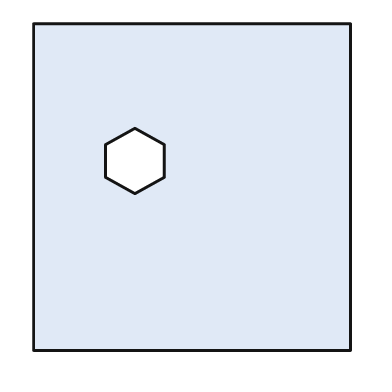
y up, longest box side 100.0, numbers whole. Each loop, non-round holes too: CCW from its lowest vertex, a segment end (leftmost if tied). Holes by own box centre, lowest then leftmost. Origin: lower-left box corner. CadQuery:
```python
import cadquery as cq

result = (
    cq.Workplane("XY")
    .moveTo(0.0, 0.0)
    .lineTo(97.0, 0.0)
    .lineTo(97.0, 100.0)
    .lineTo(0.0, 100.0)
    .close()
    .moveTo(31.0, 48.0)
    .lineTo(40.0, 53.0)
    .lineTo(40.0, 63.0)
    .lineTo(31.0, 68.0)
    .lineTo(22.0, 63.0)
    .lineTo(22.0, 53.0)
    .close()
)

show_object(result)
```